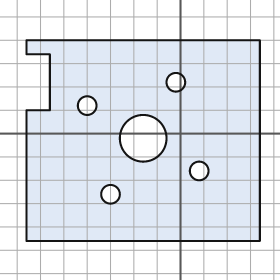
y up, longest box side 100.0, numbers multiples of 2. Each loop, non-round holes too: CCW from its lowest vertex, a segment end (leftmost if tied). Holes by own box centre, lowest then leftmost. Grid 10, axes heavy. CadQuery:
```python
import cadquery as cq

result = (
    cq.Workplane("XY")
    .moveTo(-66.0, -46.0)
    .lineTo(34.0, -46.0)
    .lineTo(34.0, 40.0)
    .lineTo(-66.0, 40.0)
    .lineTo(-66.0, 34.0)
    .lineTo(-56.0, 34.0)
    .lineTo(-56.0, 10.0)
    .lineTo(-66.0, 10.0)
    .close()
    .moveTo(-30.0, -26.0)
    .circle(4.0)
    .moveTo(8.0, -16.0)
    .circle(4.0)
    .moveTo(-16.0, -2.0)
    .circle(10.0)
    .moveTo(-40.0, 12.0)
    .circle(4.0)
    .moveTo(-2.0, 22.0)
    .circle(4.0)
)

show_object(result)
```